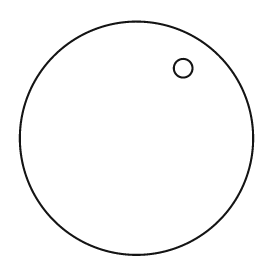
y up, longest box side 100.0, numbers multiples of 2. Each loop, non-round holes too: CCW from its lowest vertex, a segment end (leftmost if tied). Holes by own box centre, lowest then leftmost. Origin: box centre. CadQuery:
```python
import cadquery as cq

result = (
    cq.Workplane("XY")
    .moveTo(0.0, 0.0)
    .circle(50.0)
    .moveTo(20.0, 30.0)
    .circle(4.0)
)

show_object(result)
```